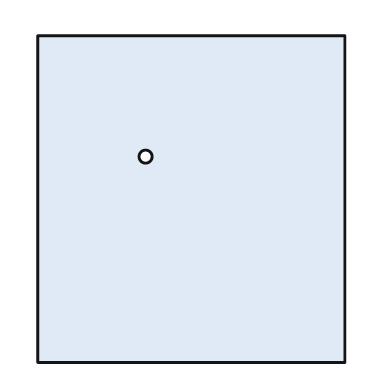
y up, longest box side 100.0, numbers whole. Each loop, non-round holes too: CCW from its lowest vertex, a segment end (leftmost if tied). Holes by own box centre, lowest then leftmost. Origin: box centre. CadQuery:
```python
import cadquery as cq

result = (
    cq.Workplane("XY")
    .moveTo(-47.0, -50.0)
    .lineTo(47.0, -50.0)
    .lineTo(47.0, 50.0)
    .lineTo(-47.0, 50.0)
    .close()
    .moveTo(-14.0, 13.0)
    .circle(2.0)
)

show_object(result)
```